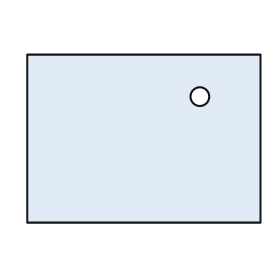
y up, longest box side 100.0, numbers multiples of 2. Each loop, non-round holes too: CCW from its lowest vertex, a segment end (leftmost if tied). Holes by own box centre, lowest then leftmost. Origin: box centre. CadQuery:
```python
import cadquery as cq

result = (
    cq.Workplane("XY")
    .moveTo(-50.0, -36.0)
    .lineTo(50.0, -36.0)
    .lineTo(50.0, 36.0)
    .lineTo(-50.0, 36.0)
    .close()
    .moveTo(24.0, 18.0)
    .circle(4.0)
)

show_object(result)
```